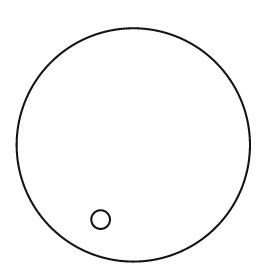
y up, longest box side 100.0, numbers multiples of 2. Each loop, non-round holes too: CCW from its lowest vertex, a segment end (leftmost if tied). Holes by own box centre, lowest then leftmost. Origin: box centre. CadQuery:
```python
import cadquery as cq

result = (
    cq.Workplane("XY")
    .moveTo(0.0, 0.0)
    .circle(50.0)
    .moveTo(-14.0, -32.0)
    .circle(4.0)
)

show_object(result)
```